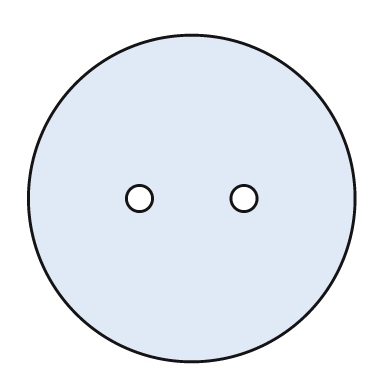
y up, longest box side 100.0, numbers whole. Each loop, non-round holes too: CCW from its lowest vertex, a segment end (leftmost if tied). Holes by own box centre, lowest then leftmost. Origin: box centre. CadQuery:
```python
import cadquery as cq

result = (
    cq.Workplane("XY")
    .moveTo(0.0, 0.0)
    .circle(50.0)
    .moveTo(-16.0, 0.0)
    .circle(4.0)
    .moveTo(16.0, 0.0)
    .circle(4.0)
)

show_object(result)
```